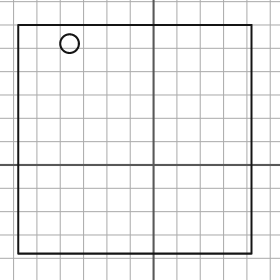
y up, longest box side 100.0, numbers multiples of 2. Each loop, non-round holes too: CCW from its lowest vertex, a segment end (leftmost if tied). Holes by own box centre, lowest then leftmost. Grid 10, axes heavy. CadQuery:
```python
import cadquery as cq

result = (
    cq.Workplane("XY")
    .moveTo(-58.0, -38.0)
    .lineTo(42.0, -38.0)
    .lineTo(42.0, 60.0)
    .lineTo(-58.0, 60.0)
    .close()
    .moveTo(-36.0, 52.0)
    .circle(4.0)
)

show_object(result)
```